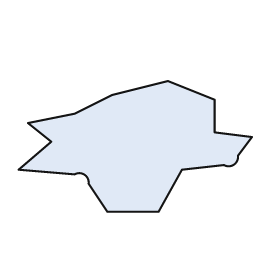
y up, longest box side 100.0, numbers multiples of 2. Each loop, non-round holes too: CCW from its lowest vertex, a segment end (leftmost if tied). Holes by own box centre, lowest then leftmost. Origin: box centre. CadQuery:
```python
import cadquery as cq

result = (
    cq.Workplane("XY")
    .moveTo(-12.0, -28.0)
    .lineTo(10.0, -28.0)
    .lineTo(20.0, -10.0)
    .lineTo(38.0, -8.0)
    .threePointArc((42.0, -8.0), (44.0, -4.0))
    .lineTo(50.0, 4.0)
    .lineTo(34.0, 6.0)
    .lineTo(34.0, 20.0)
    .lineTo(14.0, 28.0)
    .lineTo(-10.0, 22.0)
    .lineTo(-26.0, 14.0)
    .lineTo(-46.0, 10.0)
    .lineTo(-36.0, 2.0)
    .lineTo(-50.0, -10.0)
    .lineTo(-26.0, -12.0)
    .threePointArc((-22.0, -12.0), (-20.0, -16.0))
    .close()
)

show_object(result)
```